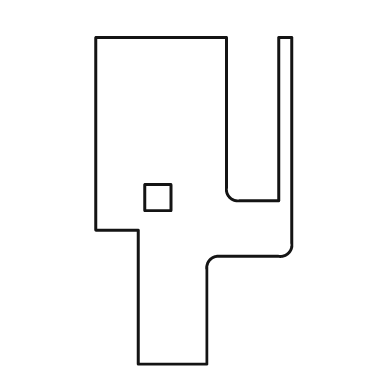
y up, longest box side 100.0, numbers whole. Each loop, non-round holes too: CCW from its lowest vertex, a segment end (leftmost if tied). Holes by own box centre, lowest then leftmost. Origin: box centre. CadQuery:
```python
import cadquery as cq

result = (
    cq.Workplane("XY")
    .moveTo(-17.0, -50.0)
    .lineTo(4.0, -50.0)
    .lineTo(4.0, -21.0)
    .threePointArc((5.0, -18.0), (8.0, -17.0))
    .lineTo(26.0, -17.0)
    .threePointArc((29.0, -16.0), (30.0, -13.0))
    .lineTo(30.0, 50.0)
    .lineTo(26.0, 50.0)
    .lineTo(26.0, 0.0)
    .lineTo(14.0, 0.0)
    .threePointArc((11.0, 1.0), (10.0, 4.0))
    .lineTo(10.0, 50.0)
    .lineTo(-30.0, 50.0)
    .lineTo(-30.0, -9.0)
    .lineTo(-17.0, -9.0)
    .close()
    .moveTo(-15.0, -3.0)
    .lineTo(-7.0, -3.0)
    .lineTo(-7.0, 5.0)
    .lineTo(-15.0, 5.0)
    .close()
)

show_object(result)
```